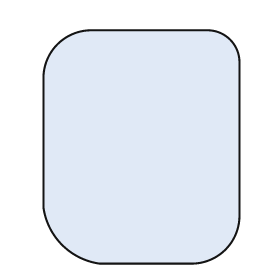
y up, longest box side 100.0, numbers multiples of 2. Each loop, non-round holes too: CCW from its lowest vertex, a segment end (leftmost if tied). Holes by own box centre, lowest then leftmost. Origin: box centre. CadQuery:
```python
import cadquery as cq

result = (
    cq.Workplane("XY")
    .moveTo(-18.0, -50.0)
    .lineTo(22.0, -50.0)
    .threePointArc((36.0, -44.0), (42.0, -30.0))
    .lineTo(42.0, 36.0)
    .threePointArc((38.0, 46.0), (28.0, 50.0))
    .lineTo(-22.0, 50.0)
    .threePointArc((-36.0, 44.0), (-42.0, 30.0))
    .lineTo(-42.0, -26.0)
    .threePointArc((-34.0, -42.0), (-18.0, -50.0))
    .close()
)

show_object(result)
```